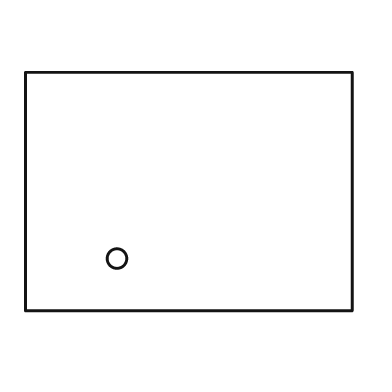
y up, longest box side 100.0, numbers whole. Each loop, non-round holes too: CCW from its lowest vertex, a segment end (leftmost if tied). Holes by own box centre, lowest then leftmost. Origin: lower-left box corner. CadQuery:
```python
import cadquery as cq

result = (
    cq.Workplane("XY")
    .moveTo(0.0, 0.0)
    .lineTo(100.0, 0.0)
    .lineTo(100.0, 73.0)
    .lineTo(0.0, 73.0)
    .close()
    .moveTo(28.0, 16.0)
    .circle(3.0)
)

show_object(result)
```